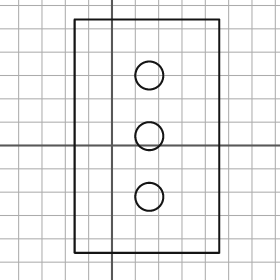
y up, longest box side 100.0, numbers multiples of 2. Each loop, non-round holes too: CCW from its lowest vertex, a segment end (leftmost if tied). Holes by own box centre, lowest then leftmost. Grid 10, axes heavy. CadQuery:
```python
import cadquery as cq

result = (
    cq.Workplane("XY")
    .moveTo(-16.0, -46.0)
    .lineTo(46.0, -46.0)
    .lineTo(46.0, 54.0)
    .lineTo(-16.0, 54.0)
    .close()
    .moveTo(16.0, -22.0)
    .circle(6.0)
    .moveTo(16.0, 4.0)
    .circle(6.0)
    .moveTo(16.0, 30.0)
    .circle(6.0)
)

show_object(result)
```